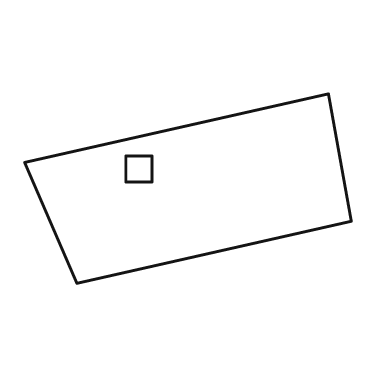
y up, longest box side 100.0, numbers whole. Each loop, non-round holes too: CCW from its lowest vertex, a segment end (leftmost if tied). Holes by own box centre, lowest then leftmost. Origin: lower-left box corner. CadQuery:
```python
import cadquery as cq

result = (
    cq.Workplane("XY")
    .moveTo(16.0, 0.0)
    .lineTo(100.0, 19.0)
    .lineTo(93.0, 58.0)
    .lineTo(0.0, 37.0)
    .close()
    .moveTo(31.0, 31.0)
    .lineTo(39.0, 31.0)
    .lineTo(39.0, 39.0)
    .lineTo(31.0, 39.0)
    .close()
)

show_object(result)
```